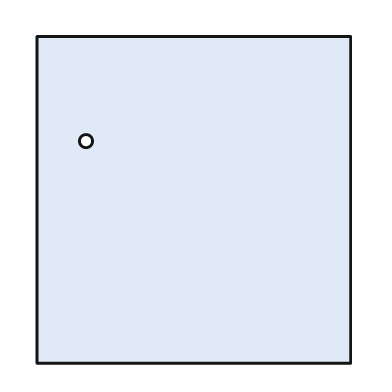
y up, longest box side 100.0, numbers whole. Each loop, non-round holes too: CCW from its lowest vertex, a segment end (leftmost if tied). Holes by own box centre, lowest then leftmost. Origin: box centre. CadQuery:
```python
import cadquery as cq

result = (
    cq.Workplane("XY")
    .moveTo(-48.0, -50.0)
    .lineTo(48.0, -50.0)
    .lineTo(48.0, 50.0)
    .lineTo(-48.0, 50.0)
    .close()
    .moveTo(-33.0, 18.0)
    .circle(2.0)
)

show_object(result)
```